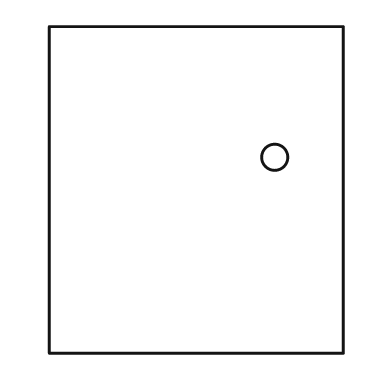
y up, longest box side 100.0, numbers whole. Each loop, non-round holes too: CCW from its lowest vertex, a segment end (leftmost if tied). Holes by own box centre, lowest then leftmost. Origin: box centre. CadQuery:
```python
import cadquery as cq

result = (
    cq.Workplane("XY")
    .moveTo(-45.0, -50.0)
    .lineTo(45.0, -50.0)
    .lineTo(45.0, 50.0)
    .lineTo(-45.0, 50.0)
    .close()
    .moveTo(24.0, 10.0)
    .circle(4.0)
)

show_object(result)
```